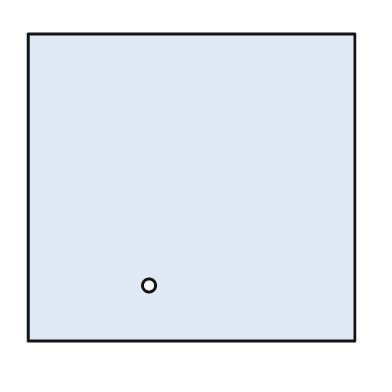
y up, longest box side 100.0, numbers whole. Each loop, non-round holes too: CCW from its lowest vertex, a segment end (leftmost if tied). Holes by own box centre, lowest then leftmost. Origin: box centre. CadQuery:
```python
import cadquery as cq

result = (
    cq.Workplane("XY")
    .moveTo(-50.0, -47.0)
    .lineTo(50.0, -47.0)
    .lineTo(50.0, 47.0)
    .lineTo(-50.0, 47.0)
    .close()
    .moveTo(-13.0, -30.0)
    .circle(2.0)
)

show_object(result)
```